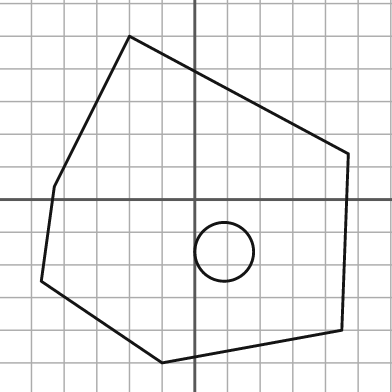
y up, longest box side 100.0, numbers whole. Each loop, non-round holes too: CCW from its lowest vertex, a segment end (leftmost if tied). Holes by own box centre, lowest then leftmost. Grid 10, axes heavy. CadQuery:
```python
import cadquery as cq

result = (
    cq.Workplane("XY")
    .moveTo(-10.0, -50.0)
    .lineTo(45.0, -40.0)
    .lineTo(47.0, 14.0)
    .lineTo(-20.0, 50.0)
    .lineTo(-43.0, 4.0)
    .lineTo(-47.0, -25.0)
    .close()
    .moveTo(9.0, -16.0)
    .circle(9.0)
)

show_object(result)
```